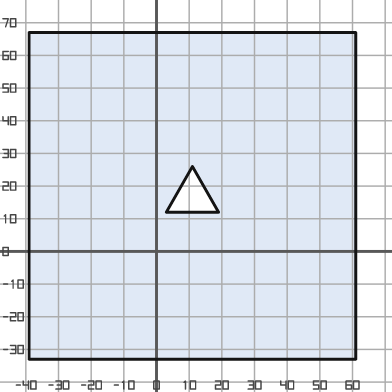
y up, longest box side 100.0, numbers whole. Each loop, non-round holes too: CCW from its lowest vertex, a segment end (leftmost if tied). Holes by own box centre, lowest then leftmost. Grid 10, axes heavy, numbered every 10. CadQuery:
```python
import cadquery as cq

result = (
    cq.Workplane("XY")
    .moveTo(-39.0, -33.0)
    .lineTo(61.0, -33.0)
    .lineTo(61.0, 67.0)
    .lineTo(-39.0, 67.0)
    .close()
    .moveTo(3.0, 12.0)
    .lineTo(19.0, 12.0)
    .lineTo(11.0, 26.0)
    .close()
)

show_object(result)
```